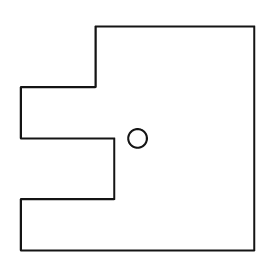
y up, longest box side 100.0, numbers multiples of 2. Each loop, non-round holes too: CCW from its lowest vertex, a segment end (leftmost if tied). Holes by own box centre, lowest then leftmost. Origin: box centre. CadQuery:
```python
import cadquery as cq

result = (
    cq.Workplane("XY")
    .moveTo(-50.0, -48.0)
    .lineTo(50.0, -48.0)
    .lineTo(50.0, 48.0)
    .lineTo(-18.0, 48.0)
    .lineTo(-18.0, 22.0)
    .lineTo(-50.0, 22.0)
    .lineTo(-50.0, 0.0)
    .lineTo(-10.0, 0.0)
    .lineTo(-10.0, -26.0)
    .lineTo(-50.0, -26.0)
    .close()
    .moveTo(0.0, 0.0)
    .circle(4.0)
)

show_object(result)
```